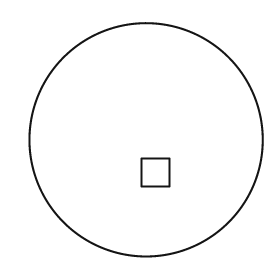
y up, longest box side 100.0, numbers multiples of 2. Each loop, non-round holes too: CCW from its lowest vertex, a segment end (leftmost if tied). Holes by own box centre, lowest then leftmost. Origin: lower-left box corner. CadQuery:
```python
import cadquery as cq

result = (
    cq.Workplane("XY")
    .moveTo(50.0, 50.0)
    .circle(50.0)
    .moveTo(48.0, 30.0)
    .lineTo(60.0, 30.0)
    .lineTo(60.0, 42.0)
    .lineTo(48.0, 42.0)
    .close()
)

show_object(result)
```